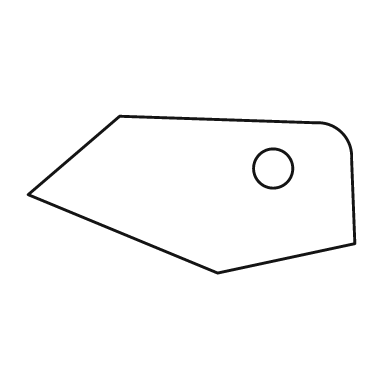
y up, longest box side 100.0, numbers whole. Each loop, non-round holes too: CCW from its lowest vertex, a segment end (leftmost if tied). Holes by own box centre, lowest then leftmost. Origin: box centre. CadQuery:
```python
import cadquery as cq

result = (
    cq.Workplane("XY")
    .moveTo(8.0, -24.0)
    .lineTo(50.0, -15.0)
    .lineTo(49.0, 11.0)
    .threePointArc((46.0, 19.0), (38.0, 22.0))
    .lineTo(-22.0, 24.0)
    .lineTo(-50.0, 0.0)
    .close()
    .moveTo(25.0, 8.0)
    .circle(6.0)
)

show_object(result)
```